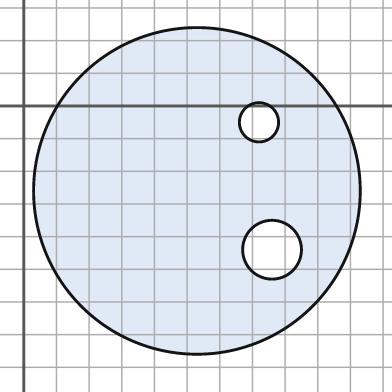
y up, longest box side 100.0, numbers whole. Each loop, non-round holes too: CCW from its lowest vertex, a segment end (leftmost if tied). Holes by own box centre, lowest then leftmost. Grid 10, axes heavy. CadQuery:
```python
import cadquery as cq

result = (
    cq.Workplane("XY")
    .moveTo(53.0, -26.0)
    .circle(50.0)
    .moveTo(76.0, -44.0)
    .circle(9.0)
    .moveTo(72.0, -5.0)
    .circle(6.0)
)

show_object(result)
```